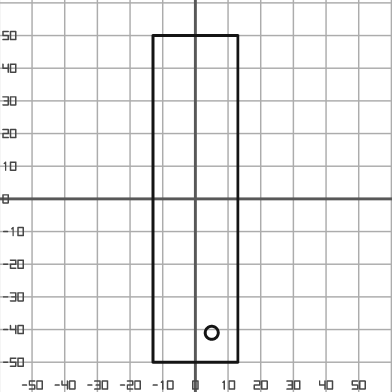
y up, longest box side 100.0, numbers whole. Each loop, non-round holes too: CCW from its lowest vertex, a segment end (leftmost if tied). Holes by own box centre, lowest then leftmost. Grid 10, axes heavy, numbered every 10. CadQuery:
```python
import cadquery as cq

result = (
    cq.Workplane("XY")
    .moveTo(-13.0, -50.0)
    .lineTo(13.0, -50.0)
    .lineTo(13.0, 50.0)
    .lineTo(-13.0, 50.0)
    .close()
    .moveTo(5.0, -41.0)
    .circle(2.0)
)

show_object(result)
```